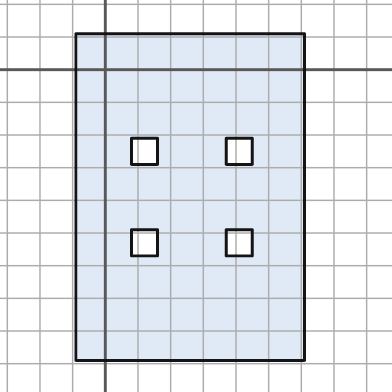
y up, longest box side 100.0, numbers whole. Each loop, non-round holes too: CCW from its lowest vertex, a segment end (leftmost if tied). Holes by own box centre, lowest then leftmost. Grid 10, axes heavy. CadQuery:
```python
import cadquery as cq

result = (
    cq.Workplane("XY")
    .moveTo(-9.0, -89.0)
    .lineTo(61.0, -89.0)
    .lineTo(61.0, 11.0)
    .lineTo(-9.0, 11.0)
    .close()
    .moveTo(8.0, -57.0)
    .lineTo(16.0, -57.0)
    .lineTo(16.0, -49.0)
    .lineTo(8.0, -49.0)
    .close()
    .moveTo(37.0, -57.0)
    .lineTo(45.0, -57.0)
    .lineTo(45.0, -49.0)
    .lineTo(37.0, -49.0)
    .close()
    .moveTo(8.0, -29.0)
    .lineTo(16.0, -29.0)
    .lineTo(16.0, -21.0)
    .lineTo(8.0, -21.0)
    .close()
    .moveTo(37.0, -29.0)
    .lineTo(45.0, -29.0)
    .lineTo(45.0, -21.0)
    .lineTo(37.0, -21.0)
    .close()
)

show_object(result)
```